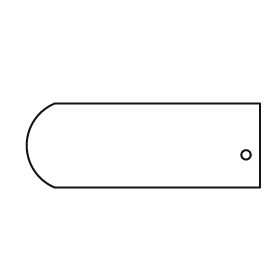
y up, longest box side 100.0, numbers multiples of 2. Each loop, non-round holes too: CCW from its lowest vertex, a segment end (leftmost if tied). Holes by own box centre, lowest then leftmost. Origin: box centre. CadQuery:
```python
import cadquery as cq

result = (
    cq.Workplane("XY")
    .moveTo(-38.0, -18.0)
    .lineTo(50.0, -18.0)
    .lineTo(50.0, 18.0)
    .lineTo(-38.0, 18.0)
    .threePointArc((-50.0, 0.0), (-38.0, -18.0))
    .close()
    .moveTo(44.0, -4.0)
    .circle(2.0)
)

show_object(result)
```